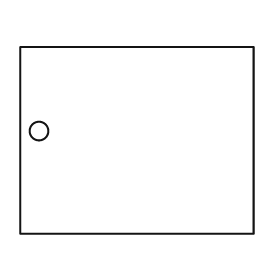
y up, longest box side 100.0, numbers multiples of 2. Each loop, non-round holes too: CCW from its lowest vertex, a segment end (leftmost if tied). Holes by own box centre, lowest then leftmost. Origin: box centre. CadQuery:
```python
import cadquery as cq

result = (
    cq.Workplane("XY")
    .moveTo(-50.0, -40.0)
    .lineTo(50.0, -40.0)
    .lineTo(50.0, 40.0)
    .lineTo(-50.0, 40.0)
    .close()
    .moveTo(-42.0, 4.0)
    .circle(4.0)
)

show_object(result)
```